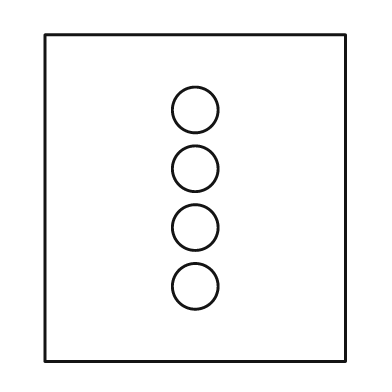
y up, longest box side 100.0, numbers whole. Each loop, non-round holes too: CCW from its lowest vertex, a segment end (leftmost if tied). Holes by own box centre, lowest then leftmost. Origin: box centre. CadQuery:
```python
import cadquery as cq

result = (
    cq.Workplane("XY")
    .moveTo(-46.0, -50.0)
    .lineTo(46.0, -50.0)
    .lineTo(46.0, 50.0)
    .lineTo(-46.0, 50.0)
    .close()
    .moveTo(0.0, -27.0)
    .circle(7.0)
    .moveTo(0.0, -9.0)
    .circle(7.0)
    .moveTo(0.0, 9.0)
    .circle(7.0)
    .moveTo(0.0, 27.0)
    .circle(7.0)
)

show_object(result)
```